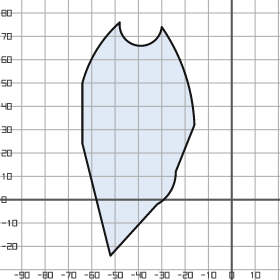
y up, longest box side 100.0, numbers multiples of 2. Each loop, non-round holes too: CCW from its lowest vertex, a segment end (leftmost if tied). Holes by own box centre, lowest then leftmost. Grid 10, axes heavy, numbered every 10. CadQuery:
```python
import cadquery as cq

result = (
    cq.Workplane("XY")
    .moveTo(-52.0, -24.0)
    .lineTo(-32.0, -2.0)
    .threePointArc((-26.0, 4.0), (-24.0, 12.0))
    .lineTo(-16.0, 32.0)
    .threePointArc((-20.0, 54.0), (-30.0, 74.0))
    .threePointArc((-40.0, 66.0), (-48.0, 76.0))
    .threePointArc((-58.0, 64.0), (-64.0, 50.0))
    .lineTo(-64.0, 24.0)
    .close()
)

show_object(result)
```